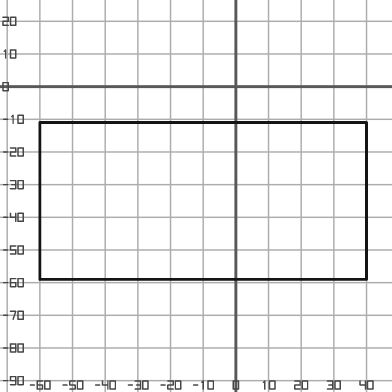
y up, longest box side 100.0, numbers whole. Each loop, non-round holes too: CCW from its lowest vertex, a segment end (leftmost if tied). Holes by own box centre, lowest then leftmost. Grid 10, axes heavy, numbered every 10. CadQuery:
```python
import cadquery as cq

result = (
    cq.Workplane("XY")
    .moveTo(-60.0, -59.0)
    .lineTo(40.0, -59.0)
    .lineTo(40.0, -11.0)
    .lineTo(-60.0, -11.0)
    .close()
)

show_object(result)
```